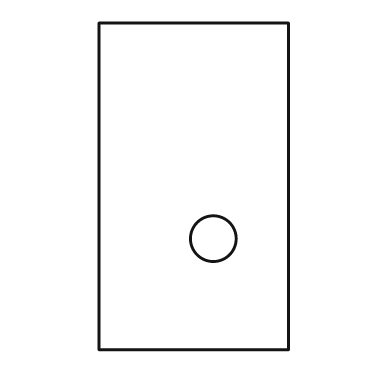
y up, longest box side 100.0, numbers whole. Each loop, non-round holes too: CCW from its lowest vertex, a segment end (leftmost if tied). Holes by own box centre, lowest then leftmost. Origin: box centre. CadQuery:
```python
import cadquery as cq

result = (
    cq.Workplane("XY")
    .moveTo(-29.0, -50.0)
    .lineTo(29.0, -50.0)
    .lineTo(29.0, 50.0)
    .lineTo(-29.0, 50.0)
    .close()
    .moveTo(6.0, -16.0)
    .circle(7.0)
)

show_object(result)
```